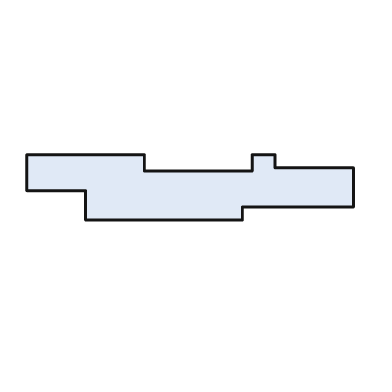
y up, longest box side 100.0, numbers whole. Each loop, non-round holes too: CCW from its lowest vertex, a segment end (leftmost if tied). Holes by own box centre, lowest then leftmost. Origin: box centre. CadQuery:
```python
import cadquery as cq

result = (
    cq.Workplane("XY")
    .moveTo(-32.0, -10.0)
    .lineTo(16.0, -10.0)
    .lineTo(16.0, -6.0)
    .lineTo(50.0, -6.0)
    .lineTo(50.0, 6.0)
    .lineTo(26.0, 6.0)
    .lineTo(26.0, 10.0)
    .lineTo(19.0, 10.0)
    .lineTo(19.0, 5.0)
    .lineTo(-14.0, 5.0)
    .lineTo(-14.0, 10.0)
    .lineTo(-50.0, 10.0)
    .lineTo(-50.0, -1.0)
    .lineTo(-32.0, -1.0)
    .close()
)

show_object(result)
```